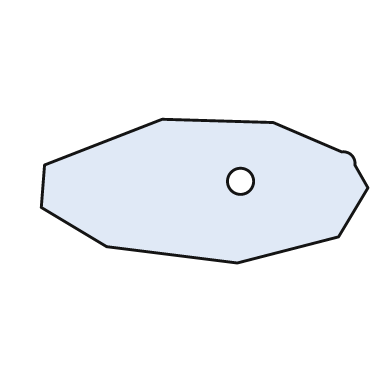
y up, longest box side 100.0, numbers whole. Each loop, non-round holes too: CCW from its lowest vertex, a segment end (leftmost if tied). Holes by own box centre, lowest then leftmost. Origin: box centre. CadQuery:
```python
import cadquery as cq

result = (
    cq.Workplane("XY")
    .moveTo(10.0, -22.0)
    .lineTo(41.0, -14.0)
    .lineTo(50.0, 1.0)
    .lineTo(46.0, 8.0)
    .threePointArc((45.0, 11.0), (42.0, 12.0))
    .lineTo(21.0, 21.0)
    .lineTo(-13.0, 22.0)
    .lineTo(-49.0, 8.0)
    .lineTo(-50.0, -5.0)
    .lineTo(-30.0, -17.0)
    .close()
    .moveTo(11.0, 3.0)
    .circle(4.0)
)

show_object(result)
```